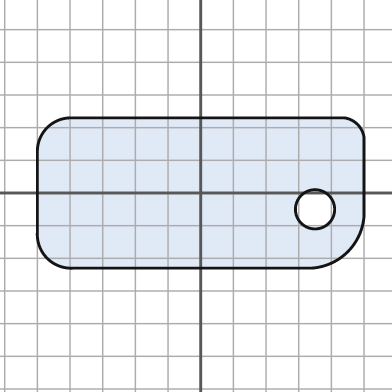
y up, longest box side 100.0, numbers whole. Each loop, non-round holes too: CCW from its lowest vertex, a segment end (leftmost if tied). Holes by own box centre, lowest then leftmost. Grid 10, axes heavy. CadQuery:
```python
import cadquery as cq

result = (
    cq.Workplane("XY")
    .moveTo(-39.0, -23.0)
    .lineTo(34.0, -23.0)
    .threePointArc((45.0, -18.0), (50.0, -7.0))
    .lineTo(50.0, 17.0)
    .threePointArc((48.0, 21.0), (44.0, 23.0))
    .lineTo(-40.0, 23.0)
    .threePointArc((-47.0, 20.0), (-50.0, 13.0))
    .lineTo(-50.0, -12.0)
    .threePointArc((-47.0, -20.0), (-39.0, -23.0))
    .close()
    .moveTo(35.0, -5.0)
    .circle(6.0)
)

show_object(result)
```